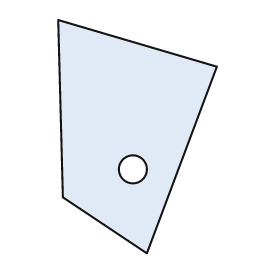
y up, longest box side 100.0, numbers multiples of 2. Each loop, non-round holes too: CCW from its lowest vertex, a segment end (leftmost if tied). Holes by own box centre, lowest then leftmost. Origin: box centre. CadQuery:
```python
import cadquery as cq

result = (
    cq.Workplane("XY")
    .moveTo(4.0, -50.0)
    .lineTo(34.0, 30.0)
    .lineTo(-34.0, 50.0)
    .lineTo(-32.0, -26.0)
    .close()
    .moveTo(-2.0, -14.0)
    .circle(6.0)
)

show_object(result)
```